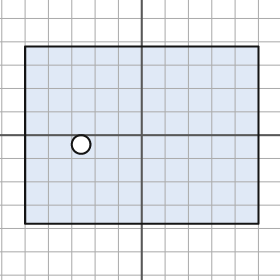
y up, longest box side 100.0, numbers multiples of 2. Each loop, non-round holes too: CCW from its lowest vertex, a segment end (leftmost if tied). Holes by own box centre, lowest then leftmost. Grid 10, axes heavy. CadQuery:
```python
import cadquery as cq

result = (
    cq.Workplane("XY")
    .moveTo(-50.0, -38.0)
    .lineTo(50.0, -38.0)
    .lineTo(50.0, 38.0)
    .lineTo(-50.0, 38.0)
    .close()
    .moveTo(-26.0, -4.0)
    .circle(4.0)
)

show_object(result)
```